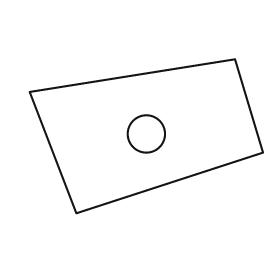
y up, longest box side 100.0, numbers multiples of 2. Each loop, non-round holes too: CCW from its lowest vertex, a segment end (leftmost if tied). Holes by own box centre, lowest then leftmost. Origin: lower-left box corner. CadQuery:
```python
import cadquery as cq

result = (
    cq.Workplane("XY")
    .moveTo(20.0, 0.0)
    .lineTo(100.0, 26.0)
    .lineTo(88.0, 66.0)
    .lineTo(0.0, 52.0)
    .close()
    .moveTo(50.0, 34.0)
    .circle(8.0)
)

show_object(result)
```